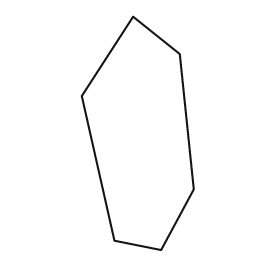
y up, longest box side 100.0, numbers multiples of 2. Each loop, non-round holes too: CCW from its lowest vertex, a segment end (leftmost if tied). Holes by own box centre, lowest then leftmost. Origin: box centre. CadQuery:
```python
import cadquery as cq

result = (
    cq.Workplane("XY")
    .moveTo(10.0, -50.0)
    .lineTo(24.0, -24.0)
    .lineTo(18.0, 34.0)
    .lineTo(-2.0, 50.0)
    .lineTo(-24.0, 16.0)
    .lineTo(-10.0, -46.0)
    .close()
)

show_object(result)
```